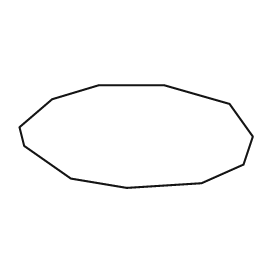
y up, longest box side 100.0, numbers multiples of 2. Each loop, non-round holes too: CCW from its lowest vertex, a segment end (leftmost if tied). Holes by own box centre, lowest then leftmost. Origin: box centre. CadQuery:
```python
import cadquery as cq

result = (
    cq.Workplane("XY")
    .moveTo(-4.0, -22.0)
    .lineTo(28.0, -20.0)
    .lineTo(46.0, -12.0)
    .lineTo(50.0, 0.0)
    .lineTo(40.0, 14.0)
    .lineTo(12.0, 22.0)
    .lineTo(-16.0, 22.0)
    .lineTo(-36.0, 16.0)
    .lineTo(-50.0, 4.0)
    .lineTo(-48.0, -4.0)
    .lineTo(-28.0, -18.0)
    .close()
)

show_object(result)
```